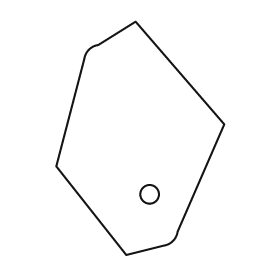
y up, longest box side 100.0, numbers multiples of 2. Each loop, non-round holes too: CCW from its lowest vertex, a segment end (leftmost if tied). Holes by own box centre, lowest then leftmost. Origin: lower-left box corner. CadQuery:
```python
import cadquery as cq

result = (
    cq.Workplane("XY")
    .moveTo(30.0, 0.0)
    .lineTo(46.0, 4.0)
    .threePointArc((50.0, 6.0), (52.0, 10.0))
    .lineTo(72.0, 56.0)
    .lineTo(34.0, 100.0)
    .lineTo(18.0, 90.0)
    .threePointArc((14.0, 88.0), (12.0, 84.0))
    .lineTo(0.0, 38.0)
    .close()
    .moveTo(40.0, 26.0)
    .circle(4.0)
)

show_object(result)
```